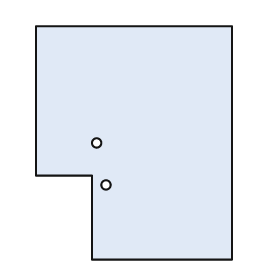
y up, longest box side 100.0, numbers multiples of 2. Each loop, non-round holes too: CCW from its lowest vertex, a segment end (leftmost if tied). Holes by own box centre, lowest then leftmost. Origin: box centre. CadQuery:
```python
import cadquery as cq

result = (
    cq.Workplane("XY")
    .moveTo(-18.0, -50.0)
    .lineTo(42.0, -50.0)
    .lineTo(42.0, 50.0)
    .lineTo(-42.0, 50.0)
    .lineTo(-42.0, -14.0)
    .lineTo(-18.0, -14.0)
    .close()
    .moveTo(-12.0, -18.0)
    .circle(2.0)
    .moveTo(-16.0, 0.0)
    .circle(2.0)
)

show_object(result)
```